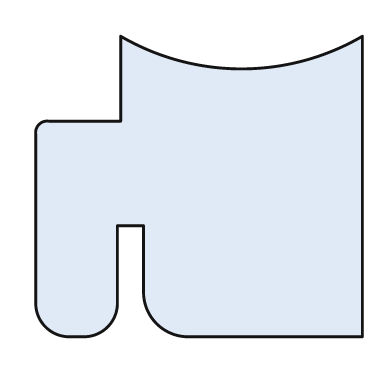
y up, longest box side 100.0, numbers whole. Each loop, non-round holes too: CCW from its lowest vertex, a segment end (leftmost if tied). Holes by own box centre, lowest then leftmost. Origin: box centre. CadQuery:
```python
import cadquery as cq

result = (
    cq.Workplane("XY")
    .moveTo(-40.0, -46.0)
    .lineTo(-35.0, -46.0)
    .threePointArc((-28.0, -43.0), (-25.0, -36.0))
    .lineTo(-25.0, -12.0)
    .lineTo(-17.0, -12.0)
    .lineTo(-17.0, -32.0)
    .threePointArc((-13.0, -42.0), (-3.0, -46.0))
    .lineTo(50.0, -46.0)
    .lineTo(50.0, 46.0)
    .threePointArc((13.0, 36.0), (-24.0, 46.0))
    .lineTo(-24.0, 20.0)
    .lineTo(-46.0, 20.0)
    .threePointArc((-49.0, 19.0), (-50.0, 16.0))
    .lineTo(-50.0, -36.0)
    .threePointArc((-47.0, -43.0), (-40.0, -46.0))
    .close()
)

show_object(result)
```